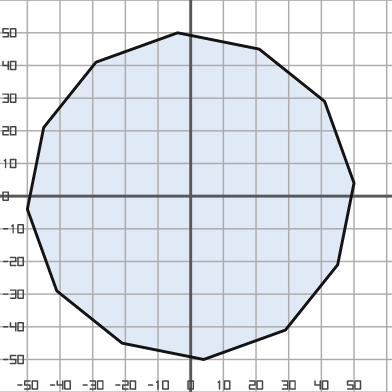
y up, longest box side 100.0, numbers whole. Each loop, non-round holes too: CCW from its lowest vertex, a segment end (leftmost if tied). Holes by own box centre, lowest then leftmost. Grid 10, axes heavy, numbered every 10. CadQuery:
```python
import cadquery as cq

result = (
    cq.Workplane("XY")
    .moveTo(4.0, -50.0)
    .lineTo(29.0, -41.0)
    .lineTo(45.0, -21.0)
    .lineTo(50.0, 4.0)
    .lineTo(41.0, 29.0)
    .lineTo(21.0, 45.0)
    .lineTo(-4.0, 50.0)
    .lineTo(-29.0, 41.0)
    .lineTo(-45.0, 21.0)
    .lineTo(-50.0, -4.0)
    .lineTo(-41.0, -29.0)
    .lineTo(-21.0, -45.0)
    .close()
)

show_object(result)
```